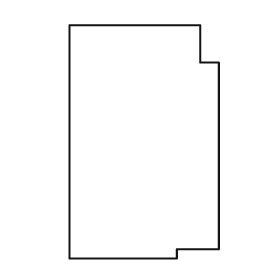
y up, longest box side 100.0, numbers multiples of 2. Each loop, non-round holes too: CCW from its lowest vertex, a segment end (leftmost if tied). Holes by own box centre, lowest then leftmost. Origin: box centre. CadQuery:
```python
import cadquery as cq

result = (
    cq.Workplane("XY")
    .moveTo(-32.0, -50.0)
    .lineTo(14.0, -50.0)
    .lineTo(14.0, -46.0)
    .lineTo(32.0, -46.0)
    .lineTo(32.0, 34.0)
    .lineTo(24.0, 34.0)
    .lineTo(24.0, 50.0)
    .lineTo(-32.0, 50.0)
    .close()
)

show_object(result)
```